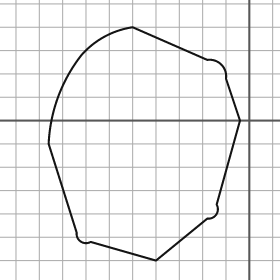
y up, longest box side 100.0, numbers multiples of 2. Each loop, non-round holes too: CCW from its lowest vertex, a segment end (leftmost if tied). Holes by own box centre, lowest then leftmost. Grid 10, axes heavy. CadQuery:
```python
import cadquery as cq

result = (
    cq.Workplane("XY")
    .moveTo(-40.0, -60.0)
    .lineTo(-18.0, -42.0)
    .threePointArc((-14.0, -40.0), (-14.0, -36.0))
    .lineTo(-4.0, 0.0)
    .lineTo(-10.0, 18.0)
    .threePointArc((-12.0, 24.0), (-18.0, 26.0))
    .lineTo(-50.0, 40.0)
    .threePointArc((-62.0, 36.0), (-72.0, 28.0))
    .threePointArc((-82.0, 10.0), (-86.0, -10.0))
    .lineTo(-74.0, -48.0)
    .threePointArc((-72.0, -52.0), (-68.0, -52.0))
    .close()
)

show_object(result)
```